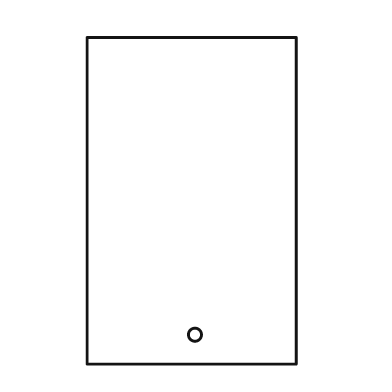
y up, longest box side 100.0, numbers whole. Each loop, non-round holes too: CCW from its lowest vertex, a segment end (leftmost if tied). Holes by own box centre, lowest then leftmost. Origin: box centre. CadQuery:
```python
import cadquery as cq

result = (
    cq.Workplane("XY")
    .moveTo(-32.0, -50.0)
    .lineTo(32.0, -50.0)
    .lineTo(32.0, 50.0)
    .lineTo(-32.0, 50.0)
    .close()
    .moveTo(1.0, -41.0)
    .circle(2.0)
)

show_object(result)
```